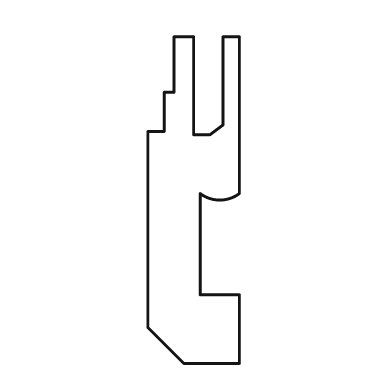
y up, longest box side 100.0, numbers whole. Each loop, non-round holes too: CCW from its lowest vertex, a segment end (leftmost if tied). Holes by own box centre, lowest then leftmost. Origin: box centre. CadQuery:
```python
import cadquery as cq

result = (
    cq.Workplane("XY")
    .moveTo(-3.0, -50.0)
    .lineTo(14.0, -50.0)
    .lineTo(14.0, -29.0)
    .lineTo(2.0, -29.0)
    .lineTo(2.0, 2.0)
    .threePointArc((8.0, 0.0), (14.0, 2.0))
    .lineTo(14.0, 50.0)
    .lineTo(9.0, 50.0)
    .lineTo(9.0, 23.0)
    .lineTo(5.0, 20.0)
    .lineTo(0.0, 20.0)
    .lineTo(0.0, 50.0)
    .lineTo(-6.0, 50.0)
    .lineTo(-6.0, 33.0)
    .lineTo(-9.0, 33.0)
    .lineTo(-9.0, 21.0)
    .lineTo(-14.0, 21.0)
    .lineTo(-14.0, -39.0)
    .close()
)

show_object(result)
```